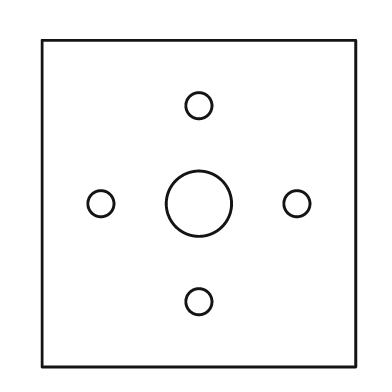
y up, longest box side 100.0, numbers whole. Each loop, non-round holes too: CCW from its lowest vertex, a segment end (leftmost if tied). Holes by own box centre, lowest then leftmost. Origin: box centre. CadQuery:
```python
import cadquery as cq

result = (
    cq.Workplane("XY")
    .moveTo(-48.0, -50.0)
    .lineTo(48.0, -50.0)
    .lineTo(48.0, 50.0)
    .lineTo(-48.0, 50.0)
    .close()
    .moveTo(0.0, -30.0)
    .circle(4.0)
    .moveTo(-30.0, 0.0)
    .circle(4.0)
    .moveTo(0.0, 0.0)
    .circle(10.0)
    .moveTo(30.0, 0.0)
    .circle(4.0)
    .moveTo(0.0, 30.0)
    .circle(4.0)
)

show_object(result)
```